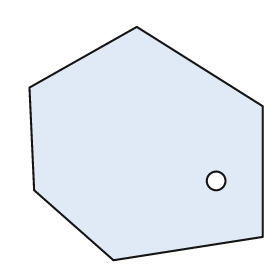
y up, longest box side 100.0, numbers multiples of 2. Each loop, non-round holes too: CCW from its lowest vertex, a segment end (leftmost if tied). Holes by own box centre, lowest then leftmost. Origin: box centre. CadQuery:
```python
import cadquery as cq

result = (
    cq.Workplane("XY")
    .moveTo(-14.0, -50.0)
    .lineTo(50.0, -40.0)
    .lineTo(50.0, 16.0)
    .lineTo(-4.0, 50.0)
    .lineTo(-50.0, 24.0)
    .lineTo(-48.0, -20.0)
    .close()
    .moveTo(30.0, -16.0)
    .circle(4.0)
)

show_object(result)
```